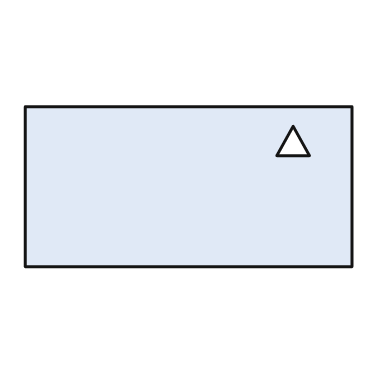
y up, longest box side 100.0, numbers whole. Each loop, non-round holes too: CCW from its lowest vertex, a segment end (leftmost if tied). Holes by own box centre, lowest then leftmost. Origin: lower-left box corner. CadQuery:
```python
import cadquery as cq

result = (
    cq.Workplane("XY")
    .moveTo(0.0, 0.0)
    .lineTo(100.0, 0.0)
    .lineTo(100.0, 49.0)
    .lineTo(0.0, 49.0)
    .close()
    .moveTo(77.0, 34.0)
    .lineTo(87.0, 34.0)
    .lineTo(82.0, 43.0)
    .close()
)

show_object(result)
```